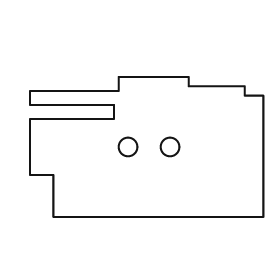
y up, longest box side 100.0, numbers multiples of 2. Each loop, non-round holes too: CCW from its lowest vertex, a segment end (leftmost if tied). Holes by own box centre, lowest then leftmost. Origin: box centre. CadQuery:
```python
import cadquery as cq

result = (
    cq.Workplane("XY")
    .moveTo(-40.0, -30.0)
    .lineTo(50.0, -30.0)
    .lineTo(50.0, 22.0)
    .lineTo(42.0, 22.0)
    .lineTo(42.0, 26.0)
    .lineTo(18.0, 26.0)
    .lineTo(18.0, 30.0)
    .lineTo(-12.0, 30.0)
    .lineTo(-12.0, 24.0)
    .lineTo(-50.0, 24.0)
    .lineTo(-50.0, 18.0)
    .lineTo(-14.0, 18.0)
    .lineTo(-14.0, 12.0)
    .lineTo(-50.0, 12.0)
    .lineTo(-50.0, -12.0)
    .lineTo(-40.0, -12.0)
    .close()
    .moveTo(-8.0, 0.0)
    .circle(4.0)
    .moveTo(10.0, 0.0)
    .circle(4.0)
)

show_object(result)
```